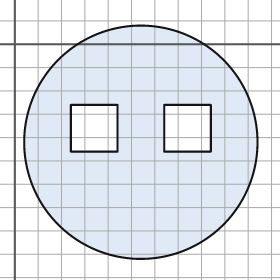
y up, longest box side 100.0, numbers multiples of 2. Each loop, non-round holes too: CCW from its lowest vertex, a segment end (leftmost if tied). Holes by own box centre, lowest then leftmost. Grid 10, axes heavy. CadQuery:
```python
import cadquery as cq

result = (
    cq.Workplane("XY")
    .moveTo(54.0, -42.0)
    .circle(50.0)
    .moveTo(24.0, -46.0)
    .lineTo(44.0, -46.0)
    .lineTo(44.0, -26.0)
    .lineTo(24.0, -26.0)
    .close()
    .moveTo(64.0, -46.0)
    .lineTo(84.0, -46.0)
    .lineTo(84.0, -26.0)
    .lineTo(64.0, -26.0)
    .close()
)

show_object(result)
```